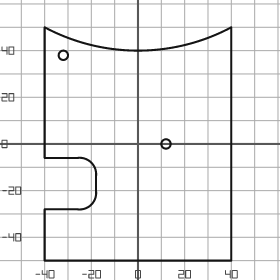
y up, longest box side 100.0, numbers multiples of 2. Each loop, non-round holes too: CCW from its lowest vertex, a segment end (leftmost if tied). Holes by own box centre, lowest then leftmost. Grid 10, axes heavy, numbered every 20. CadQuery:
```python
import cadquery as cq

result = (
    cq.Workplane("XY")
    .moveTo(-40.0, -50.0)
    .lineTo(40.0, -50.0)
    .lineTo(40.0, 50.0)
    .threePointArc((0.0, 40.0), (-40.0, 50.0))
    .lineTo(-40.0, -6.0)
    .lineTo(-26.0, -6.0)
    .threePointArc((-20.0, -8.0), (-18.0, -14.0))
    .lineTo(-18.0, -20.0)
    .threePointArc((-20.0, -26.0), (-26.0, -28.0))
    .lineTo(-40.0, -28.0)
    .close()
    .moveTo(12.0, 0.0)
    .circle(2.0)
    .moveTo(-32.0, 38.0)
    .circle(2.0)
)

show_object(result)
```